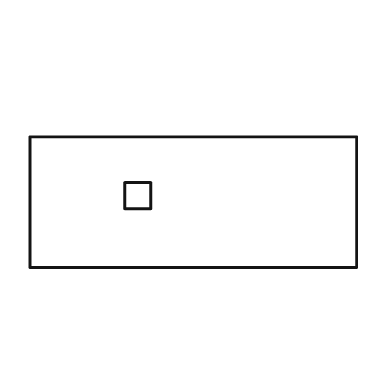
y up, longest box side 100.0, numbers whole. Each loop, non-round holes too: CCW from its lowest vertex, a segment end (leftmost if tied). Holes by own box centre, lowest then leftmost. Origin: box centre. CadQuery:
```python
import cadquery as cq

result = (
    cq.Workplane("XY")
    .moveTo(-50.0, -20.0)
    .lineTo(50.0, -20.0)
    .lineTo(50.0, 20.0)
    .lineTo(-50.0, 20.0)
    .close()
    .moveTo(-21.0, -2.0)
    .lineTo(-13.0, -2.0)
    .lineTo(-13.0, 6.0)
    .lineTo(-21.0, 6.0)
    .close()
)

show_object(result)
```